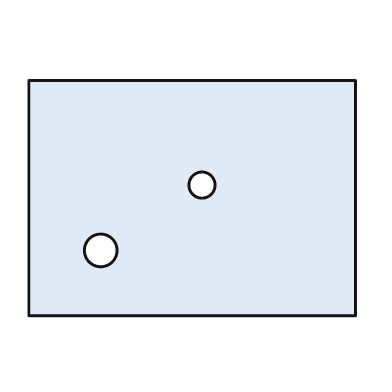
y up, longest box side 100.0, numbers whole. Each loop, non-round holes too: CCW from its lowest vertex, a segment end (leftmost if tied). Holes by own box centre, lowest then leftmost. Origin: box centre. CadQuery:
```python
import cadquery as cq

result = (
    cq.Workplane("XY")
    .moveTo(-50.0, -36.0)
    .lineTo(50.0, -36.0)
    .lineTo(50.0, 36.0)
    .lineTo(-50.0, 36.0)
    .close()
    .moveTo(-28.0, -16.0)
    .circle(5.0)
    .moveTo(3.0, 4.0)
    .circle(4.0)
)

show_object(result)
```